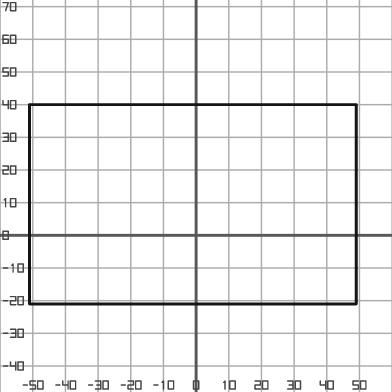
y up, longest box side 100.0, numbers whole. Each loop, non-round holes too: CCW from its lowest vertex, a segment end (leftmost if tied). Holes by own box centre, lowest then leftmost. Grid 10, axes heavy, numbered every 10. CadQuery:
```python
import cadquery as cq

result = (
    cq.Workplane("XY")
    .moveTo(-51.0, -21.0)
    .lineTo(49.0, -21.0)
    .lineTo(49.0, 40.0)
    .lineTo(-51.0, 40.0)
    .close()
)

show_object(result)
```